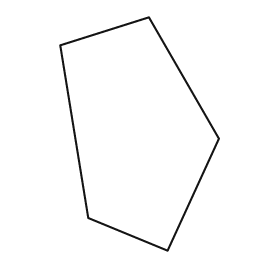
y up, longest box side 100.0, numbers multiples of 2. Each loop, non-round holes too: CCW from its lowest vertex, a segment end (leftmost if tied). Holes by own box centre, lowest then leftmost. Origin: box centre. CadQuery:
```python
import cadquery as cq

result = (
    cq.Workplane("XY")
    .moveTo(12.0, -50.0)
    .lineTo(34.0, -2.0)
    .lineTo(4.0, 50.0)
    .lineTo(-34.0, 38.0)
    .lineTo(-22.0, -36.0)
    .close()
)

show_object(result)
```